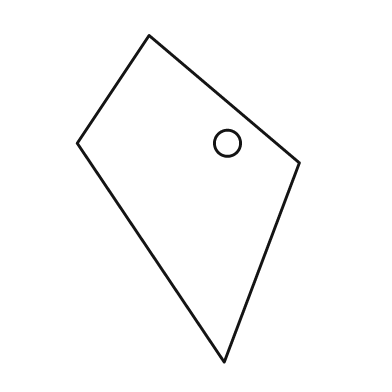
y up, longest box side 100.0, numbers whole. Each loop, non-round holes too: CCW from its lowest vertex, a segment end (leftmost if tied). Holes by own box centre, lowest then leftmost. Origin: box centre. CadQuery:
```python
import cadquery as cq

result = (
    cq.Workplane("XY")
    .moveTo(11.0, -50.0)
    .lineTo(34.0, 11.0)
    .lineTo(-12.0, 50.0)
    .lineTo(-34.0, 17.0)
    .close()
    .moveTo(12.0, 17.0)
    .circle(4.0)
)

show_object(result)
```